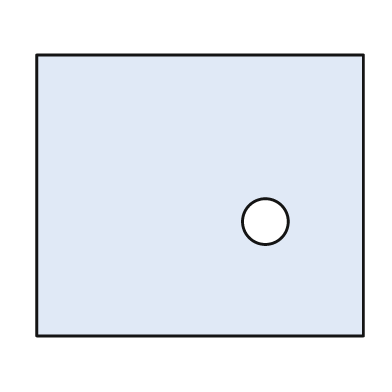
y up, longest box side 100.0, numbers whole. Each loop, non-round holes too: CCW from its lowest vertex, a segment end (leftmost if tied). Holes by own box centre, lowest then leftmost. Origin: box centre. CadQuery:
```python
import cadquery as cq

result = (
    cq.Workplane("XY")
    .moveTo(-50.0, -43.0)
    .lineTo(50.0, -43.0)
    .lineTo(50.0, 43.0)
    .lineTo(-50.0, 43.0)
    .close()
    .moveTo(20.0, -8.0)
    .circle(7.0)
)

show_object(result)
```